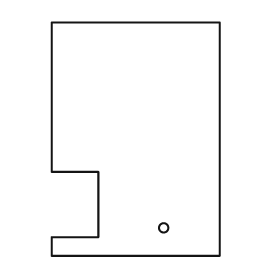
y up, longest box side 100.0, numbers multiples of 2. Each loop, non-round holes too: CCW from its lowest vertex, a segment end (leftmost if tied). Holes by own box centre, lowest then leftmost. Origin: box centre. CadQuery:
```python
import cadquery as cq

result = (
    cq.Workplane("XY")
    .moveTo(-36.0, -50.0)
    .lineTo(36.0, -50.0)
    .lineTo(36.0, 50.0)
    .lineTo(-36.0, 50.0)
    .lineTo(-36.0, -14.0)
    .lineTo(-16.0, -14.0)
    .lineTo(-16.0, -42.0)
    .lineTo(-36.0, -42.0)
    .close()
    .moveTo(12.0, -38.0)
    .circle(2.0)
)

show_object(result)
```